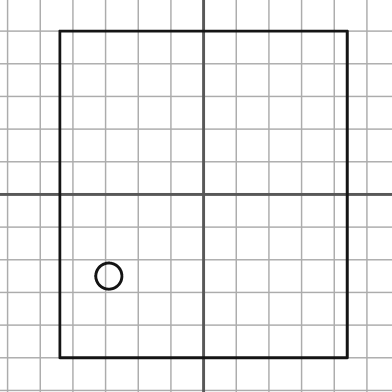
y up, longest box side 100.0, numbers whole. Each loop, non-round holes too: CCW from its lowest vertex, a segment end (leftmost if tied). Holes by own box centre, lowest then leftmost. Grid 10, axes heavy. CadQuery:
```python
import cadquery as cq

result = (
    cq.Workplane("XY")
    .moveTo(-44.0, -50.0)
    .lineTo(44.0, -50.0)
    .lineTo(44.0, 50.0)
    .lineTo(-44.0, 50.0)
    .close()
    .moveTo(-29.0, -25.0)
    .circle(4.0)
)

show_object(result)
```